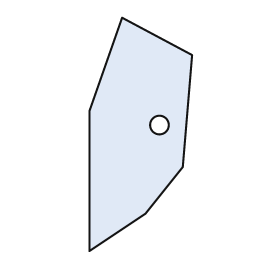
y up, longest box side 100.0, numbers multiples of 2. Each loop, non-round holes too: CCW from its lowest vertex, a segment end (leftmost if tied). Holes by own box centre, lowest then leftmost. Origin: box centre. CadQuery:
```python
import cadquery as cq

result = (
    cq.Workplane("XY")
    .moveTo(-22.0, -50.0)
    .lineTo(2.0, -34.0)
    .lineTo(18.0, -14.0)
    .lineTo(22.0, 34.0)
    .lineTo(-8.0, 50.0)
    .lineTo(-22.0, 10.0)
    .close()
    .moveTo(8.0, 4.0)
    .circle(4.0)
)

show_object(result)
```